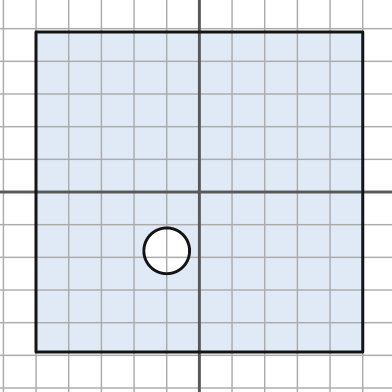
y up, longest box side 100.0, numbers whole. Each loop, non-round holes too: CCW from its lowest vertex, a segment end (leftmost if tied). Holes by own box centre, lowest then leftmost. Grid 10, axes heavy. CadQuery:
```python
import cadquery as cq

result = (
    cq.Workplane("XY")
    .moveTo(-50.0, -49.0)
    .lineTo(50.0, -49.0)
    .lineTo(50.0, 49.0)
    .lineTo(-50.0, 49.0)
    .close()
    .moveTo(-10.0, -18.0)
    .circle(7.0)
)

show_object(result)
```